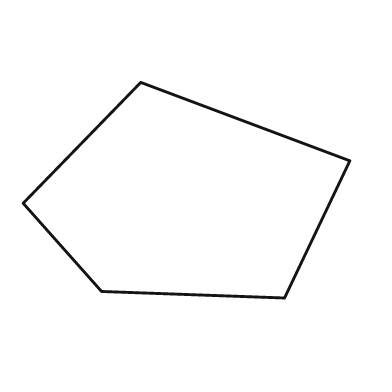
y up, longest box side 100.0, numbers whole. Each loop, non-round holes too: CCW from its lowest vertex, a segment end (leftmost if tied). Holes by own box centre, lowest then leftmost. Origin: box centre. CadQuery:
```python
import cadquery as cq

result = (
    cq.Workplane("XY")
    .moveTo(30.0, -33.0)
    .lineTo(50.0, 9.0)
    .lineTo(-14.0, 33.0)
    .lineTo(-50.0, -4.0)
    .lineTo(-26.0, -31.0)
    .close()
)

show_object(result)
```